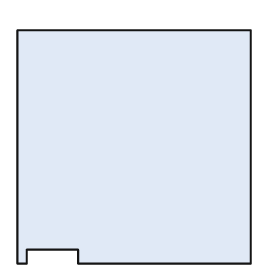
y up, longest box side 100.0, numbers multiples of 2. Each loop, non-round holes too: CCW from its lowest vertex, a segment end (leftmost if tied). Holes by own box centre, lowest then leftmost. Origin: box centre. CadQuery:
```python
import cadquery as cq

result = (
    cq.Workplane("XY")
    .moveTo(-50.0, -50.0)
    .lineTo(-46.0, -50.0)
    .lineTo(-46.0, -44.0)
    .lineTo(-24.0, -44.0)
    .lineTo(-24.0, -50.0)
    .lineTo(50.0, -50.0)
    .lineTo(50.0, 50.0)
    .lineTo(-50.0, 50.0)
    .close()
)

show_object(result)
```